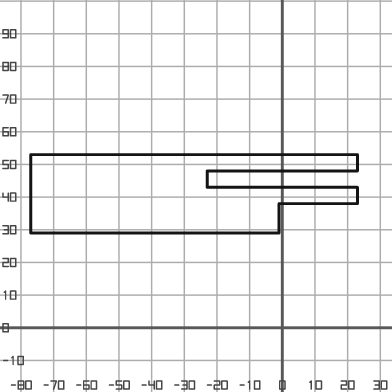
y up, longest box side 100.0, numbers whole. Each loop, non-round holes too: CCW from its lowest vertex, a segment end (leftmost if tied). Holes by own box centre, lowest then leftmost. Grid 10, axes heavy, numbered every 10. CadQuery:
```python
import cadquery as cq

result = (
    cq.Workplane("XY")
    .moveTo(-77.0, 29.0)
    .lineTo(-1.0, 29.0)
    .lineTo(-1.0, 38.0)
    .lineTo(23.0, 38.0)
    .lineTo(23.0, 43.0)
    .lineTo(-23.0, 43.0)
    .lineTo(-23.0, 48.0)
    .lineTo(23.0, 48.0)
    .lineTo(23.0, 53.0)
    .lineTo(-77.0, 53.0)
    .close()
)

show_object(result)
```